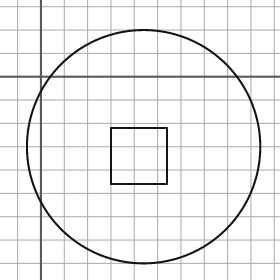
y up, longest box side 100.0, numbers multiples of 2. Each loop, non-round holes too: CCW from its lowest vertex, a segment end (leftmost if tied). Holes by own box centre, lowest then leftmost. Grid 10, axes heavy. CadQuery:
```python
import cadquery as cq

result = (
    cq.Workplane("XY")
    .moveTo(44.0, -30.0)
    .circle(50.0)
    .moveTo(30.0, -46.0)
    .lineTo(54.0, -46.0)
    .lineTo(54.0, -22.0)
    .lineTo(30.0, -22.0)
    .close()
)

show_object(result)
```